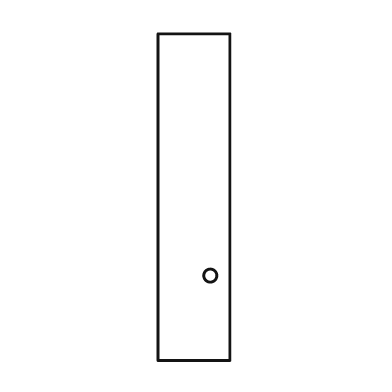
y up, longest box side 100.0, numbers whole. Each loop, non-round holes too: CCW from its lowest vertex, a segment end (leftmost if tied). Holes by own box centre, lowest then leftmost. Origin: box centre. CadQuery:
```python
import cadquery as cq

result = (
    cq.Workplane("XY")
    .moveTo(-11.0, -50.0)
    .lineTo(11.0, -50.0)
    .lineTo(11.0, 50.0)
    .lineTo(-11.0, 50.0)
    .close()
    .moveTo(5.0, -24.0)
    .circle(2.0)
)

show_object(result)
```